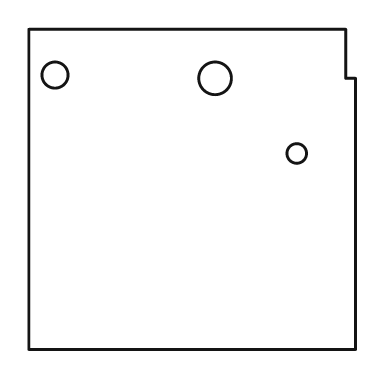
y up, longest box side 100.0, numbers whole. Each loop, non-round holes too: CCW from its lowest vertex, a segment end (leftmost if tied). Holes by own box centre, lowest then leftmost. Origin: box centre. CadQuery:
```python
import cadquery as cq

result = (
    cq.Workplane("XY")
    .moveTo(-50.0, -49.0)
    .lineTo(50.0, -49.0)
    .lineTo(50.0, 34.0)
    .lineTo(47.0, 34.0)
    .lineTo(47.0, 49.0)
    .lineTo(-50.0, 49.0)
    .close()
    .moveTo(32.0, 11.0)
    .circle(3.0)
    .moveTo(7.0, 34.0)
    .circle(5.0)
    .moveTo(-42.0, 35.0)
    .circle(4.0)
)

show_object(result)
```